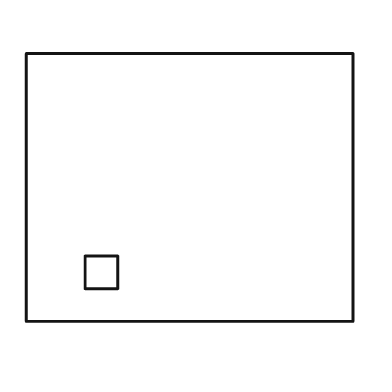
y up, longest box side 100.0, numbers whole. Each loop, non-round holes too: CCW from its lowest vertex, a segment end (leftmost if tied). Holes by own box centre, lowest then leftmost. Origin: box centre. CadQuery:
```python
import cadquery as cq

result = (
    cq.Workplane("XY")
    .moveTo(-50.0, -41.0)
    .lineTo(50.0, -41.0)
    .lineTo(50.0, 41.0)
    .lineTo(-50.0, 41.0)
    .close()
    .moveTo(-32.0, -31.0)
    .lineTo(-22.0, -31.0)
    .lineTo(-22.0, -21.0)
    .lineTo(-32.0, -21.0)
    .close()
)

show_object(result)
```